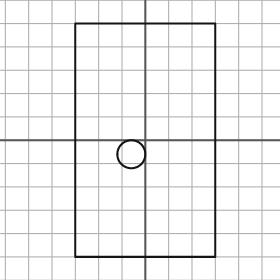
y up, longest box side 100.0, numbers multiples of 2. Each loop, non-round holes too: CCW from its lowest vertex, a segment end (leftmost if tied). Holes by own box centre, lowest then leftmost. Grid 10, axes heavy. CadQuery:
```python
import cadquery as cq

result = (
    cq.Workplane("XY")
    .moveTo(-30.0, -50.0)
    .lineTo(30.0, -50.0)
    .lineTo(30.0, 50.0)
    .lineTo(-30.0, 50.0)
    .close()
    .moveTo(-6.0, -6.0)
    .circle(6.0)
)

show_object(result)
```